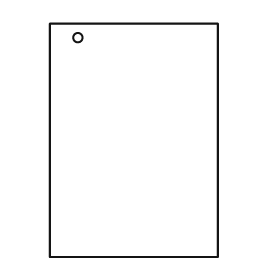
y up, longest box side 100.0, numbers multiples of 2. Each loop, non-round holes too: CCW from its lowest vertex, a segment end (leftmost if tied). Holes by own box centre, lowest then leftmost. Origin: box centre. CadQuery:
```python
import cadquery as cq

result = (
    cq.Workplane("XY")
    .moveTo(-36.0, -50.0)
    .lineTo(36.0, -50.0)
    .lineTo(36.0, 50.0)
    .lineTo(-36.0, 50.0)
    .close()
    .moveTo(-24.0, 44.0)
    .circle(2.0)
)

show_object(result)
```